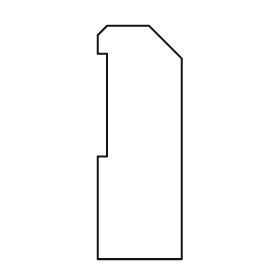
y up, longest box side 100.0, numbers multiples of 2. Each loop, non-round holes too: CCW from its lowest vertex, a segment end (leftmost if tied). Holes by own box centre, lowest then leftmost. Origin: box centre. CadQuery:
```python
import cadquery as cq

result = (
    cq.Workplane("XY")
    .moveTo(-18.0, -50.0)
    .lineTo(18.0, -50.0)
    .lineTo(18.0, 36.0)
    .lineTo(4.0, 50.0)
    .lineTo(-14.0, 50.0)
    .lineTo(-18.0, 46.0)
    .lineTo(-18.0, 38.0)
    .lineTo(-14.0, 38.0)
    .lineTo(-14.0, -6.0)
    .lineTo(-18.0, -6.0)
    .close()
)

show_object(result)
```